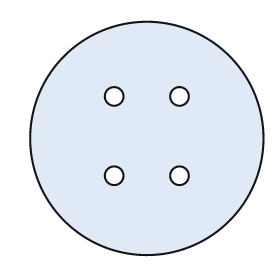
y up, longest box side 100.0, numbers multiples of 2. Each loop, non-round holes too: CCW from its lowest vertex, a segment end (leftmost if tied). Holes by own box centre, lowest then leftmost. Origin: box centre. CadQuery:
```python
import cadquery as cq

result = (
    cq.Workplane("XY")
    .moveTo(0.0, 0.0)
    .circle(50.0)
    .moveTo(-14.0, -16.0)
    .circle(4.0)
    .moveTo(14.0, -16.0)
    .circle(4.0)
    .moveTo(-14.0, 18.0)
    .circle(4.0)
    .moveTo(14.0, 18.0)
    .circle(4.0)
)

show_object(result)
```